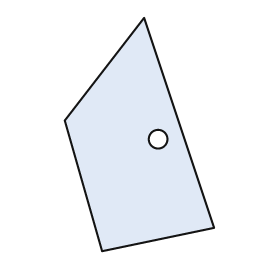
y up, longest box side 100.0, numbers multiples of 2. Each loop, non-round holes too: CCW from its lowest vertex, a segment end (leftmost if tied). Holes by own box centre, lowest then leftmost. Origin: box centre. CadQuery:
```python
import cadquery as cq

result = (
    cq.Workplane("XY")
    .moveTo(-16.0, -50.0)
    .lineTo(32.0, -40.0)
    .lineTo(2.0, 50.0)
    .lineTo(-32.0, 6.0)
    .close()
    .moveTo(8.0, -2.0)
    .circle(4.0)
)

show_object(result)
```